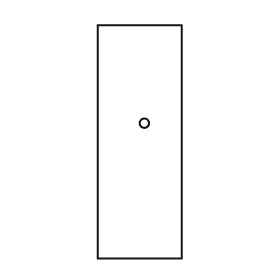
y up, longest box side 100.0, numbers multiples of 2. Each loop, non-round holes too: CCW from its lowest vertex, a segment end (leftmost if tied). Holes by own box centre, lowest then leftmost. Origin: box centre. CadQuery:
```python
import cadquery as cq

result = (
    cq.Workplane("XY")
    .moveTo(-18.0, -50.0)
    .lineTo(18.0, -50.0)
    .lineTo(18.0, 50.0)
    .lineTo(-18.0, 50.0)
    .close()
    .moveTo(2.0, 8.0)
    .circle(2.0)
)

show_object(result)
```